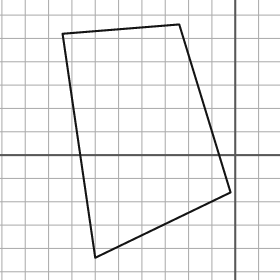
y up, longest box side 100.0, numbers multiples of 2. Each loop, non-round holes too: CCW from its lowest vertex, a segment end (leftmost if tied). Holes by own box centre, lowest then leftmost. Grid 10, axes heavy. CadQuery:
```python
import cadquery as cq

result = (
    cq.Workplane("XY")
    .moveTo(-60.0, -44.0)
    .lineTo(-2.0, -16.0)
    .lineTo(-24.0, 56.0)
    .lineTo(-74.0, 52.0)
    .close()
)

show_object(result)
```